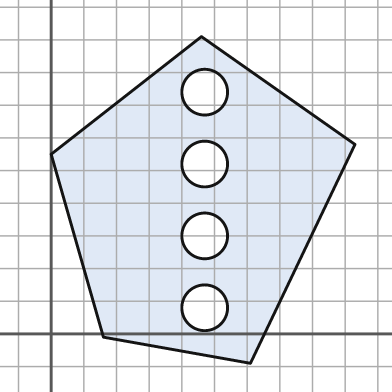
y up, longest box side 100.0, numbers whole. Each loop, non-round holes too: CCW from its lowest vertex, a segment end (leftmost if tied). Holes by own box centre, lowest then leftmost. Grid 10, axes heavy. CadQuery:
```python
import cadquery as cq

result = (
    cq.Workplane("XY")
    .moveTo(61.0, -9.0)
    .lineTo(93.0, 58.0)
    .lineTo(46.0, 91.0)
    .lineTo(0.0, 55.0)
    .lineTo(16.0, -1.0)
    .close()
    .moveTo(47.0, 8.0)
    .circle(7.0)
    .moveTo(47.0, 30.0)
    .circle(7.0)
    .moveTo(47.0, 52.0)
    .circle(7.0)
    .moveTo(47.0, 74.0)
    .circle(7.0)
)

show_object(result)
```